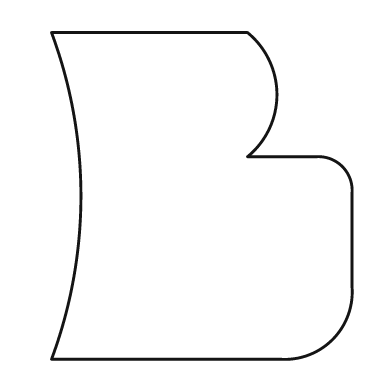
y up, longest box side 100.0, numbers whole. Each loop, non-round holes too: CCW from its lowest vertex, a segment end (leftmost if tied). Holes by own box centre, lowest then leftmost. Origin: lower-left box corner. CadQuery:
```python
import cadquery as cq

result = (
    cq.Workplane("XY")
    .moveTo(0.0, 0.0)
    .lineTo(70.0, 0.0)
    .threePointArc((86.0, 6.0), (92.0, 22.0))
    .lineTo(92.0, 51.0)
    .threePointArc((89.0, 59.0), (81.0, 62.0))
    .lineTo(60.0, 62.0)
    .threePointArc((69.0, 81.0), (60.0, 100.0))
    .lineTo(0.0, 100.0)
    .threePointArc((9.0, 50.0), (0.0, 0.0))
    .close()
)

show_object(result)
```